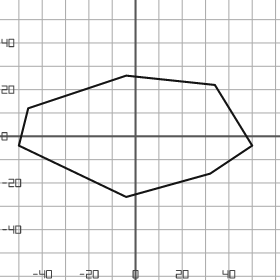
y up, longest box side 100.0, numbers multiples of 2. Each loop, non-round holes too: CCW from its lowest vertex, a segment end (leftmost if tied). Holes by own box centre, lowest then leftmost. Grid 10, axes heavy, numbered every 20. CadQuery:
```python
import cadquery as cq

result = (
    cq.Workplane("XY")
    .moveTo(-4.0, -26.0)
    .lineTo(32.0, -16.0)
    .lineTo(50.0, -4.0)
    .lineTo(34.0, 22.0)
    .lineTo(-4.0, 26.0)
    .lineTo(-46.0, 12.0)
    .lineTo(-50.0, -4.0)
    .close()
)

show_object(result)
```